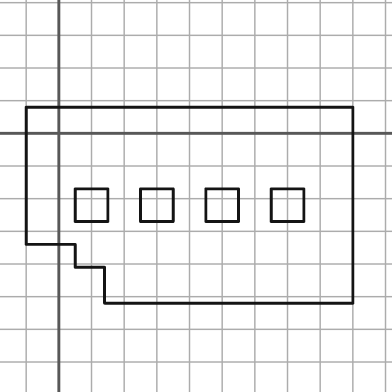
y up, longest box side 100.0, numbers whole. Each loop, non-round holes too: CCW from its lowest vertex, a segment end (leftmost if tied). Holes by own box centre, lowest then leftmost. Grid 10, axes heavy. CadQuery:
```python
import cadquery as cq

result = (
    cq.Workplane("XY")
    .moveTo(14.0, -52.0)
    .lineTo(90.0, -52.0)
    .lineTo(90.0, 8.0)
    .lineTo(-10.0, 8.0)
    .lineTo(-10.0, -34.0)
    .lineTo(5.0, -34.0)
    .lineTo(5.0, -41.0)
    .lineTo(14.0, -41.0)
    .close()
    .moveTo(5.0, -27.0)
    .lineTo(15.0, -27.0)
    .lineTo(15.0, -17.0)
    .lineTo(5.0, -17.0)
    .close()
    .moveTo(25.0, -27.0)
    .lineTo(35.0, -27.0)
    .lineTo(35.0, -17.0)
    .lineTo(25.0, -17.0)
    .close()
    .moveTo(45.0, -27.0)
    .lineTo(55.0, -27.0)
    .lineTo(55.0, -17.0)
    .lineTo(45.0, -17.0)
    .close()
    .moveTo(65.0, -27.0)
    .lineTo(75.0, -27.0)
    .lineTo(75.0, -17.0)
    .lineTo(65.0, -17.0)
    .close()
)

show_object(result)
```